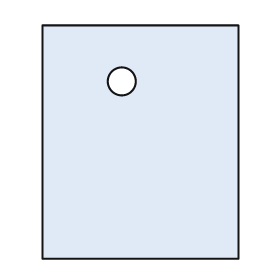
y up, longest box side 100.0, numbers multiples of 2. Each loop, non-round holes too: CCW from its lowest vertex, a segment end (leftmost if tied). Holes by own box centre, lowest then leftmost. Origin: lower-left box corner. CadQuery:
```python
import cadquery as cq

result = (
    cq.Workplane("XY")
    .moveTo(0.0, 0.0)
    .lineTo(84.0, 0.0)
    .lineTo(84.0, 100.0)
    .lineTo(0.0, 100.0)
    .close()
    .moveTo(34.0, 76.0)
    .circle(6.0)
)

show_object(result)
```